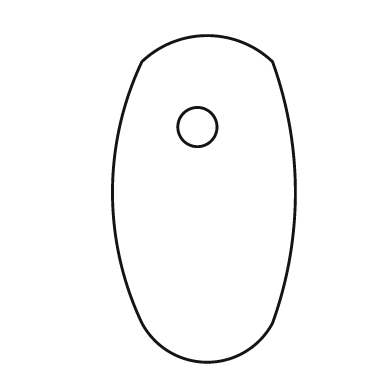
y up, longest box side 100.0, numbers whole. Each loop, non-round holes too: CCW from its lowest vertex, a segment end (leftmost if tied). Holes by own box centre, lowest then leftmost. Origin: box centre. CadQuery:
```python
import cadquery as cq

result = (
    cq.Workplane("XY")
    .moveTo(-19.0, -38.0)
    .threePointArc((1.0, -50.0), (21.0, -38.0))
    .threePointArc((28.0, 2.0), (21.0, 42.0))
    .threePointArc((1.0, 50.0), (-19.0, 42.0))
    .threePointArc((-28.0, 2.0), (-19.0, -38.0))
    .close()
    .moveTo(-2.0, 22.0)
    .circle(6.0)
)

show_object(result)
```